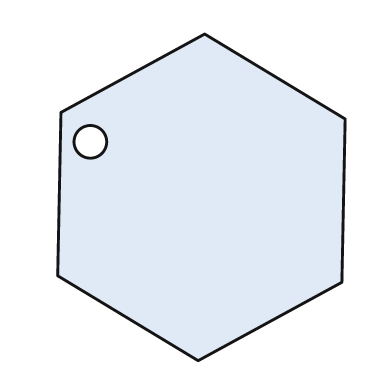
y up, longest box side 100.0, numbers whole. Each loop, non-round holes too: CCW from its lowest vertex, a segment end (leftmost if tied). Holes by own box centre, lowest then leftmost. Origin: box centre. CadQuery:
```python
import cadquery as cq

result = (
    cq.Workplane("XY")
    .moveTo(-1.0, -50.0)
    .lineTo(43.0, -26.0)
    .lineTo(44.0, 24.0)
    .lineTo(1.0, 50.0)
    .lineTo(-43.0, 26.0)
    .lineTo(-44.0, -24.0)
    .close()
    .moveTo(-34.0, 17.0)
    .circle(5.0)
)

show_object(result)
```